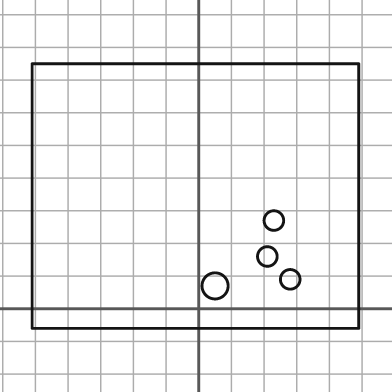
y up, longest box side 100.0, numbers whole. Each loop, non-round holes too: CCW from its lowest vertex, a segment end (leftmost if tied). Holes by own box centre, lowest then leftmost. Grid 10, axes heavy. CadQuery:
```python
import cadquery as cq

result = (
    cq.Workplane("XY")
    .moveTo(-51.0, -6.0)
    .lineTo(49.0, -6.0)
    .lineTo(49.0, 75.0)
    .lineTo(-51.0, 75.0)
    .close()
    .moveTo(5.0, 7.0)
    .circle(4.0)
    .moveTo(28.0, 9.0)
    .circle(3.0)
    .moveTo(21.0, 16.0)
    .circle(3.0)
    .moveTo(23.0, 27.0)
    .circle(3.0)
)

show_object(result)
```